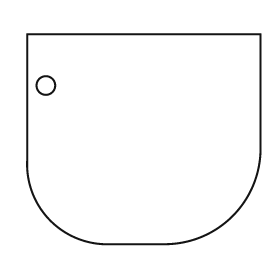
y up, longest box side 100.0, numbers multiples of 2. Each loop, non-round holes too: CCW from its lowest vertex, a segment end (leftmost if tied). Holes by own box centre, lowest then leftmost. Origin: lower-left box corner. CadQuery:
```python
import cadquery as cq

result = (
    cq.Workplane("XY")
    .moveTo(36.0, 0.0)
    .lineTo(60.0, 0.0)
    .threePointArc((88.0, 12.0), (100.0, 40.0))
    .lineTo(100.0, 90.0)
    .lineTo(0.0, 90.0)
    .lineTo(0.0, 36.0)
    .threePointArc((10.0, 10.0), (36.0, 0.0))
    .close()
    .moveTo(8.0, 68.0)
    .circle(4.0)
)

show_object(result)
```